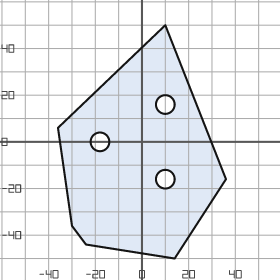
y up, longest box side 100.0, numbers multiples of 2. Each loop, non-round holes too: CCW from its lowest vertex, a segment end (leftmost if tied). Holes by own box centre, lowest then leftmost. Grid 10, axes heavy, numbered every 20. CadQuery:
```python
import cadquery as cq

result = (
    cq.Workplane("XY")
    .moveTo(14.0, -50.0)
    .lineTo(36.0, -16.0)
    .lineTo(10.0, 50.0)
    .lineTo(-36.0, 6.0)
    .lineTo(-30.0, -36.0)
    .lineTo(-24.0, -44.0)
    .close()
    .moveTo(10.0, -16.0)
    .circle(4.0)
    .moveTo(-18.0, 0.0)
    .circle(4.0)
    .moveTo(10.0, 16.0)
    .circle(4.0)
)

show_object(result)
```